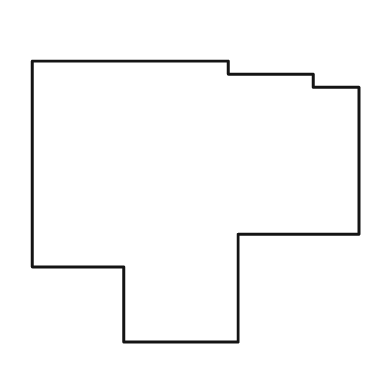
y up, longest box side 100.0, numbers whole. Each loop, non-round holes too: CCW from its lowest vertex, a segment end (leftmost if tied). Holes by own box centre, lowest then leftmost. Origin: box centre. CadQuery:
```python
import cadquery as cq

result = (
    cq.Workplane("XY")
    .moveTo(-22.0, -43.0)
    .lineTo(13.0, -43.0)
    .lineTo(13.0, -10.0)
    .lineTo(50.0, -10.0)
    .lineTo(50.0, 35.0)
    .lineTo(36.0, 35.0)
    .lineTo(36.0, 39.0)
    .lineTo(10.0, 39.0)
    .lineTo(10.0, 43.0)
    .lineTo(-50.0, 43.0)
    .lineTo(-50.0, -20.0)
    .lineTo(-22.0, -20.0)
    .close()
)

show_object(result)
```